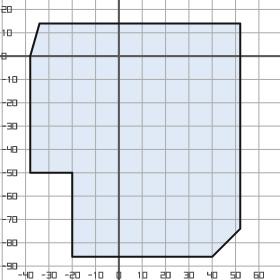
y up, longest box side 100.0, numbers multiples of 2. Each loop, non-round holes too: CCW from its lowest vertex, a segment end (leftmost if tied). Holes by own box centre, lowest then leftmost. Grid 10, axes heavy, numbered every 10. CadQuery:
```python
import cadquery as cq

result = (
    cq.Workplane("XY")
    .moveTo(-20.0, -86.0)
    .lineTo(40.0, -86.0)
    .lineTo(52.0, -74.0)
    .lineTo(52.0, 14.0)
    .lineTo(-34.0, 14.0)
    .lineTo(-38.0, 0.0)
    .lineTo(-38.0, -50.0)
    .lineTo(-20.0, -50.0)
    .close()
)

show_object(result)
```